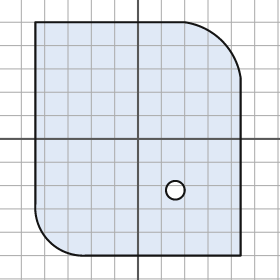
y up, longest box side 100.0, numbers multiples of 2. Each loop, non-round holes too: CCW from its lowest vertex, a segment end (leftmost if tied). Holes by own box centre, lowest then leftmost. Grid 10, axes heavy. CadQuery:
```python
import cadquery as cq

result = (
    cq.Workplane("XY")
    .moveTo(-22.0, -50.0)
    .lineTo(44.0, -50.0)
    .lineTo(44.0, 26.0)
    .threePointArc((36.0, 42.0), (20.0, 50.0))
    .lineTo(-44.0, 50.0)
    .lineTo(-44.0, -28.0)
    .threePointArc((-38.0, -44.0), (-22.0, -50.0))
    .close()
    .moveTo(16.0, -22.0)
    .circle(4.0)
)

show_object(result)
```